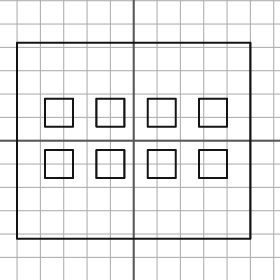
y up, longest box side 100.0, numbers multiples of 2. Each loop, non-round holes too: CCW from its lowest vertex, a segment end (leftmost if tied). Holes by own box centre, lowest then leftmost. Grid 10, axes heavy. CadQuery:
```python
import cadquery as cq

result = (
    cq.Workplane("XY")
    .moveTo(-50.0, -42.0)
    .lineTo(50.0, -42.0)
    .lineTo(50.0, 42.0)
    .lineTo(-50.0, 42.0)
    .close()
    .moveTo(-38.0, -16.0)
    .lineTo(-26.0, -16.0)
    .lineTo(-26.0, -4.0)
    .lineTo(-38.0, -4.0)
    .close()
    .moveTo(-16.0, -16.0)
    .lineTo(-4.0, -16.0)
    .lineTo(-4.0, -4.0)
    .lineTo(-16.0, -4.0)
    .close()
    .moveTo(6.0, -16.0)
    .lineTo(18.0, -16.0)
    .lineTo(18.0, -4.0)
    .lineTo(6.0, -4.0)
    .close()
    .moveTo(28.0, -16.0)
    .lineTo(40.0, -16.0)
    .lineTo(40.0, -4.0)
    .lineTo(28.0, -4.0)
    .close()
    .moveTo(-38.0, 6.0)
    .lineTo(-26.0, 6.0)
    .lineTo(-26.0, 18.0)
    .lineTo(-38.0, 18.0)
    .close()
    .moveTo(-16.0, 6.0)
    .lineTo(-4.0, 6.0)
    .lineTo(-4.0, 18.0)
    .lineTo(-16.0, 18.0)
    .close()
    .moveTo(6.0, 6.0)
    .lineTo(18.0, 6.0)
    .lineTo(18.0, 18.0)
    .lineTo(6.0, 18.0)
    .close()
    .moveTo(28.0, 6.0)
    .lineTo(40.0, 6.0)
    .lineTo(40.0, 18.0)
    .lineTo(28.0, 18.0)
    .close()
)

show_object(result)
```